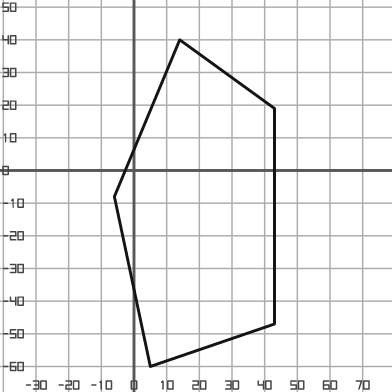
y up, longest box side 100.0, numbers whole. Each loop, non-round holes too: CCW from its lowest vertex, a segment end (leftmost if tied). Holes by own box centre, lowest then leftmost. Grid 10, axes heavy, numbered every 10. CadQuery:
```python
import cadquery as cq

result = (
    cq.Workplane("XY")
    .moveTo(5.0, -60.0)
    .lineTo(43.0, -47.0)
    .lineTo(43.0, 19.0)
    .lineTo(14.0, 40.0)
    .lineTo(-6.0, -8.0)
    .close()
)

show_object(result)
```